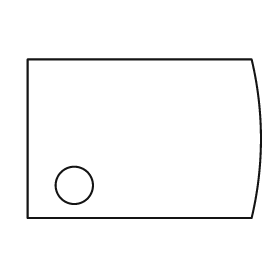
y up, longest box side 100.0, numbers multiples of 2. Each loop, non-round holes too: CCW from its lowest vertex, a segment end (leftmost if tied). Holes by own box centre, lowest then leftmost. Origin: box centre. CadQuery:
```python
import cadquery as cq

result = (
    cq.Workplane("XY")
    .moveTo(-50.0, -34.0)
    .lineTo(46.0, -34.0)
    .threePointArc((50.0, 0.0), (46.0, 34.0))
    .lineTo(-50.0, 34.0)
    .close()
    .moveTo(-30.0, -20.0)
    .circle(8.0)
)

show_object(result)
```